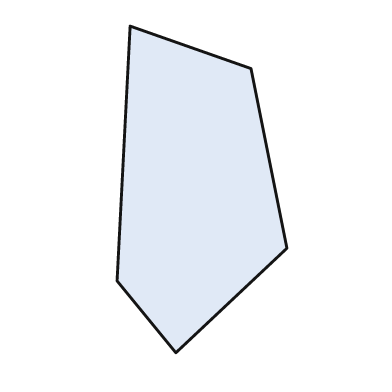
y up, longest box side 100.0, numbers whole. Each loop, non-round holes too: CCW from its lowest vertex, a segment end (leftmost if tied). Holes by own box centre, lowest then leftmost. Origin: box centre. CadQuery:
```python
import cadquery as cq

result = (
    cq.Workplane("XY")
    .moveTo(-8.0, -50.0)
    .lineTo(26.0, -18.0)
    .lineTo(15.0, 37.0)
    .lineTo(-22.0, 50.0)
    .lineTo(-26.0, -28.0)
    .close()
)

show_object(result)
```